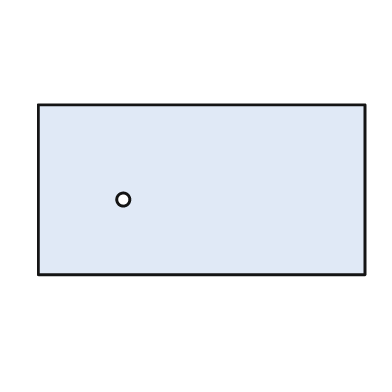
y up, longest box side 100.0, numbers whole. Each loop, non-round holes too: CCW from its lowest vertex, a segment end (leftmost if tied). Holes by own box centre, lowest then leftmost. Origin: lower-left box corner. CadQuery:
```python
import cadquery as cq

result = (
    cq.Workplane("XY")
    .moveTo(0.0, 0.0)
    .lineTo(100.0, 0.0)
    .lineTo(100.0, 52.0)
    .lineTo(0.0, 52.0)
    .close()
    .moveTo(26.0, 23.0)
    .circle(2.0)
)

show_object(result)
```